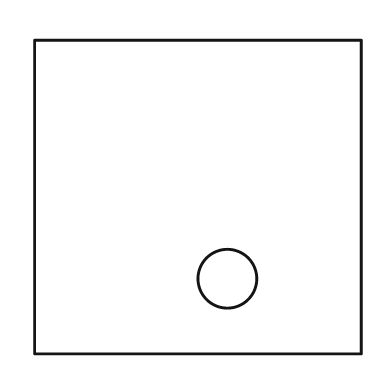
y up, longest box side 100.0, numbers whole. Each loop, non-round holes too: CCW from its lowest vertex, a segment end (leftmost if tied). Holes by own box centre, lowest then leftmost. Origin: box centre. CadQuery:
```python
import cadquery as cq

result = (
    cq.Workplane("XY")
    .moveTo(-50.0, -48.0)
    .lineTo(50.0, -48.0)
    .lineTo(50.0, 48.0)
    .lineTo(-50.0, 48.0)
    .close()
    .moveTo(9.0, -25.0)
    .circle(9.0)
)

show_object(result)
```